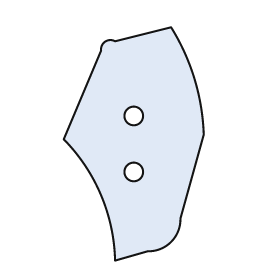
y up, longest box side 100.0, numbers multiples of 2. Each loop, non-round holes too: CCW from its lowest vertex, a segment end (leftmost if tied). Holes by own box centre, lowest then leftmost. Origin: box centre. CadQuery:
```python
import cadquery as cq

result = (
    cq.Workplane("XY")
    .moveTo(-8.0, -50.0)
    .lineTo(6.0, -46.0)
    .threePointArc((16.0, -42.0), (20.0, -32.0))
    .lineTo(30.0, 4.0)
    .threePointArc((26.0, 28.0), (16.0, 50.0))
    .lineTo(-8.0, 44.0)
    .threePointArc((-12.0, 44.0), (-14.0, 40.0))
    .lineTo(-30.0, 2.0)
    .threePointArc((-14.0, -22.0), (-8.0, -50.0))
    .close()
    .moveTo(0.0, -12.0)
    .circle(4.0)
    .moveTo(0.0, 12.0)
    .circle(4.0)
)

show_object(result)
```